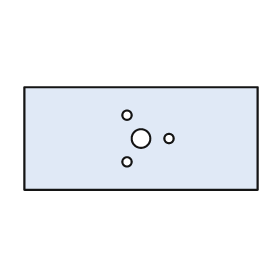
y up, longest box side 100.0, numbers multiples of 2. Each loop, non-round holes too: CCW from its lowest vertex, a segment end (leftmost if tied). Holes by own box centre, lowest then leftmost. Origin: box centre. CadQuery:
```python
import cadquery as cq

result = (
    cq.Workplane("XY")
    .moveTo(-50.0, -22.0)
    .lineTo(50.0, -22.0)
    .lineTo(50.0, 22.0)
    .lineTo(-50.0, 22.0)
    .close()
    .moveTo(-6.0, -10.0)
    .circle(2.0)
    .moveTo(0.0, 0.0)
    .circle(4.0)
    .moveTo(12.0, 0.0)
    .circle(2.0)
    .moveTo(-6.0, 10.0)
    .circle(2.0)
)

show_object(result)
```